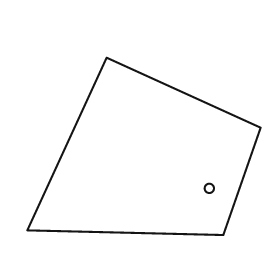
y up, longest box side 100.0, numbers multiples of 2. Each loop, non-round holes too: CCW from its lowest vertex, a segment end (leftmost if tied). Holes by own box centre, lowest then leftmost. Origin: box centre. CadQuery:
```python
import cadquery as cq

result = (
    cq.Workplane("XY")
    .moveTo(34.0, -38.0)
    .lineTo(50.0, 8.0)
    .lineTo(-16.0, 38.0)
    .lineTo(-50.0, -36.0)
    .close()
    .moveTo(28.0, -18.0)
    .circle(2.0)
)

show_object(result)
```